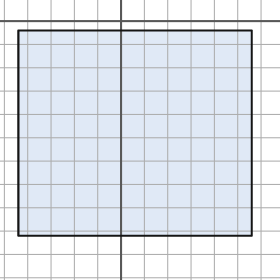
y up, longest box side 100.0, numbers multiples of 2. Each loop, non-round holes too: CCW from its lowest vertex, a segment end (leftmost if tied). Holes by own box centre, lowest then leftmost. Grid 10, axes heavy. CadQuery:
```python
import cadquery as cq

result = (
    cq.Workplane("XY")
    .moveTo(-44.0, -92.0)
    .lineTo(56.0, -92.0)
    .lineTo(56.0, -4.0)
    .lineTo(-44.0, -4.0)
    .close()
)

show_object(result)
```